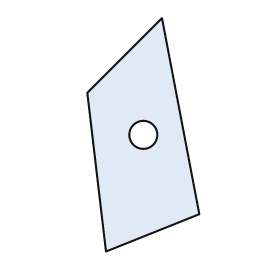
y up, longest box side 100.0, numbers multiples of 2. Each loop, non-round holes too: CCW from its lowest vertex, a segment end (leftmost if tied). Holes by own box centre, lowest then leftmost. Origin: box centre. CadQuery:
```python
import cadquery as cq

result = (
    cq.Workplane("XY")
    .moveTo(-16.0, -50.0)
    .lineTo(24.0, -34.0)
    .lineTo(8.0, 50.0)
    .lineTo(-24.0, 18.0)
    .close()
    .moveTo(0.0, 0.0)
    .circle(6.0)
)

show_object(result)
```